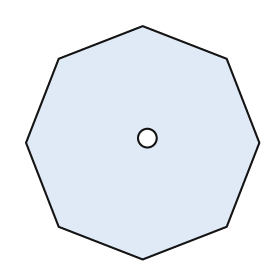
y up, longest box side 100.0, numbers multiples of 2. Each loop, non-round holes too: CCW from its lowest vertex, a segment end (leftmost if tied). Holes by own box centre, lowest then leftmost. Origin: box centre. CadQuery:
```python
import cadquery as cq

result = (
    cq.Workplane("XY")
    .moveTo(0.0, -50.0)
    .lineTo(36.0, -36.0)
    .lineTo(50.0, 0.0)
    .lineTo(36.0, 36.0)
    .lineTo(0.0, 50.0)
    .lineTo(-36.0, 36.0)
    .lineTo(-50.0, 0.0)
    .lineTo(-36.0, -36.0)
    .close()
    .moveTo(2.0, 2.0)
    .circle(4.0)
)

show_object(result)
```